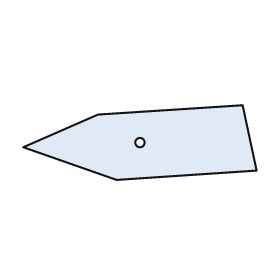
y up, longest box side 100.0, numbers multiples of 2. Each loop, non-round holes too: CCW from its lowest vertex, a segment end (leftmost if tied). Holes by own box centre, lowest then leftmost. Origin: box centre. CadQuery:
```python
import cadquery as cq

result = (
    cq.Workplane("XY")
    .moveTo(-10.0, -16.0)
    .lineTo(50.0, -12.0)
    .lineTo(44.0, 16.0)
    .lineTo(-18.0, 12.0)
    .lineTo(-50.0, -2.0)
    .close()
    .moveTo(0.0, 0.0)
    .circle(2.0)
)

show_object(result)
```